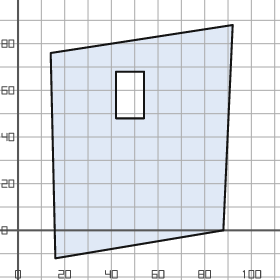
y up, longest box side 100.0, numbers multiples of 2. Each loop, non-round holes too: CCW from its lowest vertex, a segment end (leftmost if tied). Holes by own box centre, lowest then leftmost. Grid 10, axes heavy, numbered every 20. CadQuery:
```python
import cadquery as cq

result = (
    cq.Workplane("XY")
    .moveTo(16.0, -12.0)
    .lineTo(88.0, 0.0)
    .lineTo(92.0, 88.0)
    .lineTo(14.0, 76.0)
    .close()
    .moveTo(42.0, 48.0)
    .lineTo(54.0, 48.0)
    .lineTo(54.0, 68.0)
    .lineTo(42.0, 68.0)
    .close()
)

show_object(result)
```